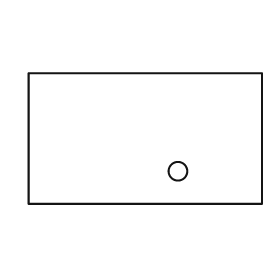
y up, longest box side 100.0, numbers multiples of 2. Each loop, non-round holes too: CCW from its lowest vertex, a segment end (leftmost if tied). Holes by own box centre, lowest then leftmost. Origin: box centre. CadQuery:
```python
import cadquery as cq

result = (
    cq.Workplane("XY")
    .moveTo(-50.0, -28.0)
    .lineTo(50.0, -28.0)
    .lineTo(50.0, 28.0)
    .lineTo(-50.0, 28.0)
    .close()
    .moveTo(14.0, -14.0)
    .circle(4.0)
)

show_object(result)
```